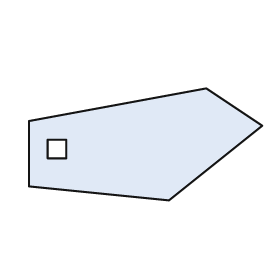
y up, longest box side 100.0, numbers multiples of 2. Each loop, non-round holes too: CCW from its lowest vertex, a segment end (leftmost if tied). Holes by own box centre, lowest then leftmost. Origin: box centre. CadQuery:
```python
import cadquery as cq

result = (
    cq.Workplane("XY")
    .moveTo(10.0, -24.0)
    .lineTo(50.0, 8.0)
    .lineTo(26.0, 24.0)
    .lineTo(-50.0, 10.0)
    .lineTo(-50.0, -18.0)
    .close()
    .moveTo(-42.0, -6.0)
    .lineTo(-34.0, -6.0)
    .lineTo(-34.0, 2.0)
    .lineTo(-42.0, 2.0)
    .close()
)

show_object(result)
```